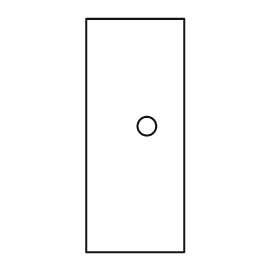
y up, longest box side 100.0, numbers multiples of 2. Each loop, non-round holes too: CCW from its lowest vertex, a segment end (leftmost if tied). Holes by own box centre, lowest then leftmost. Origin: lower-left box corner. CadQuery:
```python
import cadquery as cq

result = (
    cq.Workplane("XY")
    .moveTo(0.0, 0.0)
    .lineTo(42.0, 0.0)
    .lineTo(42.0, 100.0)
    .lineTo(0.0, 100.0)
    .close()
    .moveTo(26.0, 54.0)
    .circle(4.0)
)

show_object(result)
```